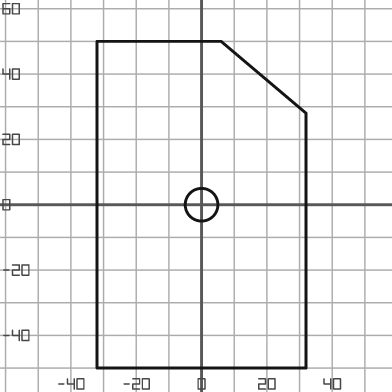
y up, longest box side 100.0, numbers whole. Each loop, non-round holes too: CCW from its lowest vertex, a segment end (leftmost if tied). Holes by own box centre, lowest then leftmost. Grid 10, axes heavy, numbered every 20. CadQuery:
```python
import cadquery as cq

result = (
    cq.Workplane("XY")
    .moveTo(-32.0, -50.0)
    .lineTo(32.0, -50.0)
    .lineTo(32.0, 28.0)
    .lineTo(6.0, 50.0)
    .lineTo(-32.0, 50.0)
    .close()
    .moveTo(0.0, 0.0)
    .circle(5.0)
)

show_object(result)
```